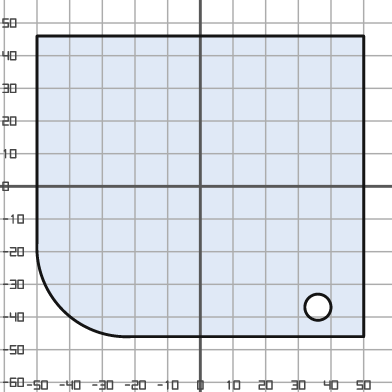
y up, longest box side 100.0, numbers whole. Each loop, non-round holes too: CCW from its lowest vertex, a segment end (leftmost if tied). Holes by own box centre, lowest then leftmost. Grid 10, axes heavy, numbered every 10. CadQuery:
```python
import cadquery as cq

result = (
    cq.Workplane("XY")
    .moveTo(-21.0, -46.0)
    .lineTo(50.0, -46.0)
    .lineTo(50.0, 46.0)
    .lineTo(-50.0, 46.0)
    .lineTo(-50.0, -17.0)
    .threePointArc((-42.0, -38.0), (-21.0, -46.0))
    .close()
    .moveTo(36.0, -37.0)
    .circle(4.0)
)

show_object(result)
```